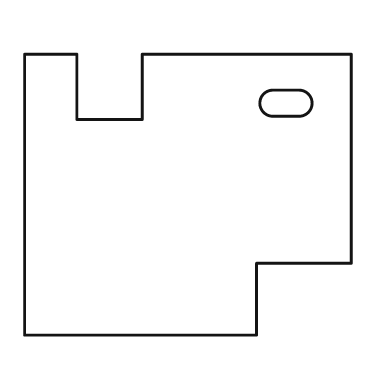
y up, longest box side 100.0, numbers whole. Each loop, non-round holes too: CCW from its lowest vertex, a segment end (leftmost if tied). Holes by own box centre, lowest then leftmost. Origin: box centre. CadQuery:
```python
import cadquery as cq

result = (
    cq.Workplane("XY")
    .moveTo(-50.0, -43.0)
    .lineTo(21.0, -43.0)
    .lineTo(21.0, -21.0)
    .lineTo(50.0, -21.0)
    .lineTo(50.0, 43.0)
    .lineTo(-14.0, 43.0)
    .lineTo(-14.0, 23.0)
    .lineTo(-34.0, 23.0)
    .lineTo(-34.0, 43.0)
    .lineTo(-50.0, 43.0)
    .close()
    .moveTo(26.0, 24.0)
    .lineTo(34.0, 24.0)
    .threePointArc((38.0, 28.0), (34.0, 32.0))
    .lineTo(26.0, 32.0)
    .threePointArc((22.0, 28.0), (26.0, 24.0))
    .close()
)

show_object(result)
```